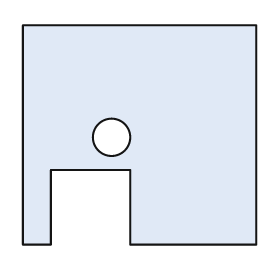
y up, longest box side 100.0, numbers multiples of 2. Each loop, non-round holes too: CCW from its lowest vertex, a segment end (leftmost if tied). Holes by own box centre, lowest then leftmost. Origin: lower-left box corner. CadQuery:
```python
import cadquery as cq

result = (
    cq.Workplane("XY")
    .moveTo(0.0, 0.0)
    .lineTo(12.0, 0.0)
    .lineTo(12.0, 32.0)
    .lineTo(46.0, 32.0)
    .lineTo(46.0, 0.0)
    .lineTo(100.0, 0.0)
    .lineTo(100.0, 94.0)
    .lineTo(0.0, 94.0)
    .close()
    .moveTo(38.0, 46.0)
    .circle(8.0)
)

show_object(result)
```